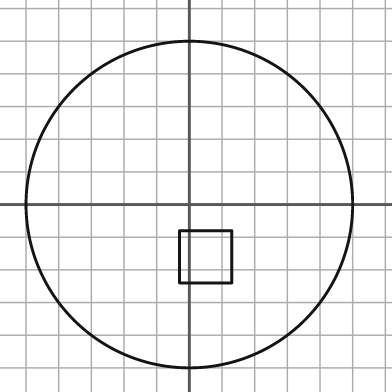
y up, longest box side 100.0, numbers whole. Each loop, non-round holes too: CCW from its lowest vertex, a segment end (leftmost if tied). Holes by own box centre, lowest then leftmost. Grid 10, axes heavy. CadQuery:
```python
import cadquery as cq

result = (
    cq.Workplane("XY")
    .moveTo(0.0, 0.0)
    .circle(50.0)
    .moveTo(-3.0, -24.0)
    .lineTo(13.0, -24.0)
    .lineTo(13.0, -8.0)
    .lineTo(-3.0, -8.0)
    .close()
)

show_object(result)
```